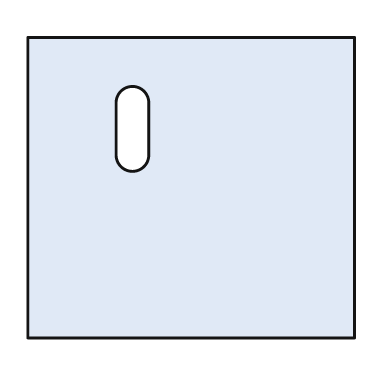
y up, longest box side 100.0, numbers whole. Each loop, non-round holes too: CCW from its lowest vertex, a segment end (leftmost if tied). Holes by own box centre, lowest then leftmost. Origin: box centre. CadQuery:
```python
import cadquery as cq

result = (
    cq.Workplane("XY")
    .moveTo(-50.0, -46.0)
    .lineTo(50.0, -46.0)
    .lineTo(50.0, 46.0)
    .lineTo(-50.0, 46.0)
    .close()
    .moveTo(-23.0, 10.0)
    .threePointArc((-18.0, 5.0), (-13.0, 10.0))
    .lineTo(-13.0, 26.0)
    .threePointArc((-18.0, 31.0), (-23.0, 26.0))
    .close()
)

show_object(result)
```